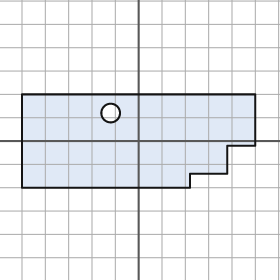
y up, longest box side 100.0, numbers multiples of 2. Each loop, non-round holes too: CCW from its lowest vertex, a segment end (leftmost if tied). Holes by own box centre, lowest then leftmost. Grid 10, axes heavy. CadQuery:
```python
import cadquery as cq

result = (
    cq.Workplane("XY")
    .moveTo(-50.0, -20.0)
    .lineTo(22.0, -20.0)
    .lineTo(22.0, -14.0)
    .lineTo(38.0, -14.0)
    .lineTo(38.0, -2.0)
    .lineTo(50.0, -2.0)
    .lineTo(50.0, 20.0)
    .lineTo(-50.0, 20.0)
    .close()
    .moveTo(-12.0, 12.0)
    .circle(4.0)
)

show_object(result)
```